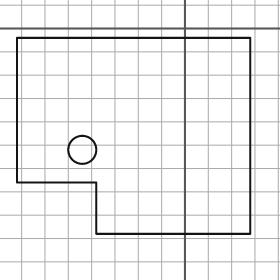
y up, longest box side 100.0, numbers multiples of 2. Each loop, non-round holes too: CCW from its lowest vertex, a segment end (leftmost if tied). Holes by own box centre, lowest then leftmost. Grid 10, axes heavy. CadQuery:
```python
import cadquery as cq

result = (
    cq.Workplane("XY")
    .moveTo(-38.0, -88.0)
    .lineTo(28.0, -88.0)
    .lineTo(28.0, -4.0)
    .lineTo(-72.0, -4.0)
    .lineTo(-72.0, -66.0)
    .lineTo(-38.0, -66.0)
    .close()
    .moveTo(-44.0, -52.0)
    .circle(6.0)
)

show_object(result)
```